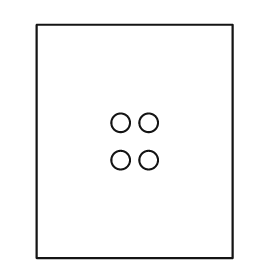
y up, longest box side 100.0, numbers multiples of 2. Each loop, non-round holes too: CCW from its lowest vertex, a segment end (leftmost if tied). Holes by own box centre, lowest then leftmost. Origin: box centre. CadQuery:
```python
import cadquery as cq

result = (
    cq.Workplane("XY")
    .moveTo(-42.0, -50.0)
    .lineTo(42.0, -50.0)
    .lineTo(42.0, 50.0)
    .lineTo(-42.0, 50.0)
    .close()
    .moveTo(-6.0, -8.0)
    .circle(4.0)
    .moveTo(6.0, -8.0)
    .circle(4.0)
    .moveTo(-6.0, 8.0)
    .circle(4.0)
    .moveTo(6.0, 8.0)
    .circle(4.0)
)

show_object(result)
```